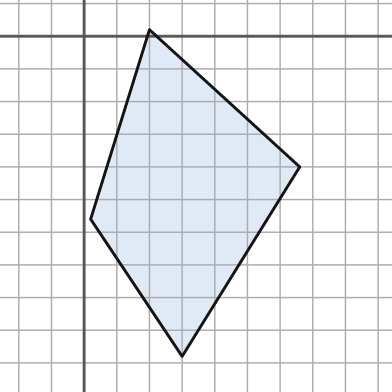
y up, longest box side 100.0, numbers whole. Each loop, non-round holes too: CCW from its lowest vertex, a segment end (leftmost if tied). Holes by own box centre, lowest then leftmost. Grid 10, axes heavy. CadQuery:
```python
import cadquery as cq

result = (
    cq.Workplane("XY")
    .moveTo(30.0, -98.0)
    .lineTo(66.0, -40.0)
    .lineTo(20.0, 2.0)
    .lineTo(2.0, -56.0)
    .close()
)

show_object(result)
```